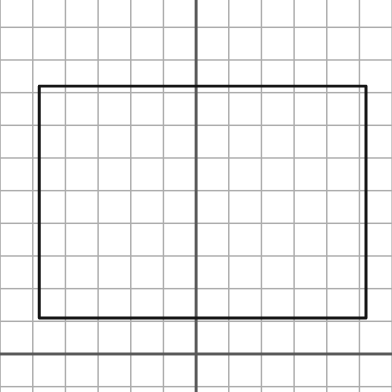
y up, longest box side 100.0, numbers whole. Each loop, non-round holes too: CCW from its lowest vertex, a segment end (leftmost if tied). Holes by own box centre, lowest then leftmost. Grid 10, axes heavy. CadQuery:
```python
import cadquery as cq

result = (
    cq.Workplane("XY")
    .moveTo(-48.0, 11.0)
    .lineTo(52.0, 11.0)
    .lineTo(52.0, 82.0)
    .lineTo(-48.0, 82.0)
    .close()
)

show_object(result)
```